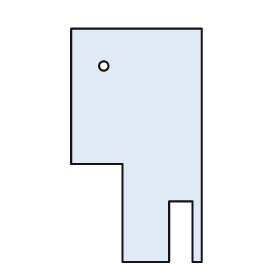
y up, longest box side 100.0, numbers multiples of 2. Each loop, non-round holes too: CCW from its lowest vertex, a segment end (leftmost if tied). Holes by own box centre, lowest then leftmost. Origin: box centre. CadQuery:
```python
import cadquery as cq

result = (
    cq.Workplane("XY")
    .moveTo(-6.0, -50.0)
    .lineTo(14.0, -50.0)
    .lineTo(14.0, -24.0)
    .lineTo(24.0, -24.0)
    .lineTo(24.0, -50.0)
    .lineTo(28.0, -50.0)
    .lineTo(28.0, 50.0)
    .lineTo(-28.0, 50.0)
    .lineTo(-28.0, -8.0)
    .lineTo(-6.0, -8.0)
    .close()
    .moveTo(-14.0, 34.0)
    .circle(2.0)
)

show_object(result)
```